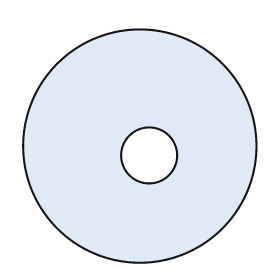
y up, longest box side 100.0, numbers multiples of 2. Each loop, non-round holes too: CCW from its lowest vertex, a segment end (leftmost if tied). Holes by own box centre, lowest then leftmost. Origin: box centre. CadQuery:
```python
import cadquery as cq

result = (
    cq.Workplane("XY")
    .moveTo(0.0, 0.0)
    .circle(50.0)
    .moveTo(4.0, -4.0)
    .circle(12.0)
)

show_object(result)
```